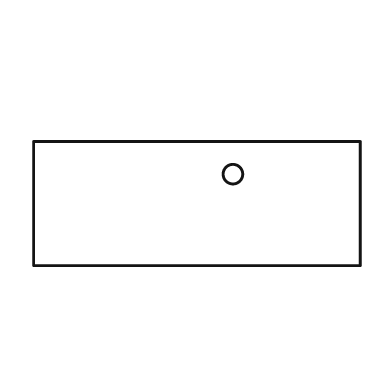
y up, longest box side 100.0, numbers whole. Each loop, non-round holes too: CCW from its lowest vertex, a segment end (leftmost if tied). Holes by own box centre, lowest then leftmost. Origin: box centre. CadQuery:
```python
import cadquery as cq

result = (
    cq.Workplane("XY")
    .moveTo(-50.0, -19.0)
    .lineTo(50.0, -19.0)
    .lineTo(50.0, 19.0)
    .lineTo(-50.0, 19.0)
    .close()
    .moveTo(11.0, 9.0)
    .circle(3.0)
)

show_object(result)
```